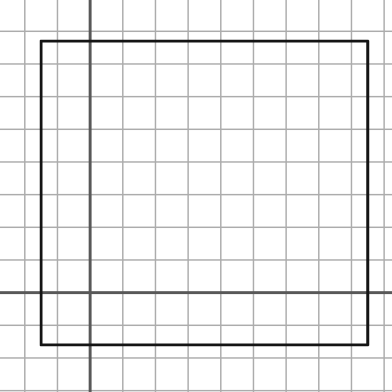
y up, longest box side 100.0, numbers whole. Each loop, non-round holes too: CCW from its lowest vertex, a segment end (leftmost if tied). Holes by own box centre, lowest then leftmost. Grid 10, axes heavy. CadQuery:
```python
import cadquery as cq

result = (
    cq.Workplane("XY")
    .moveTo(-15.0, -16.0)
    .lineTo(85.0, -16.0)
    .lineTo(85.0, 77.0)
    .lineTo(-15.0, 77.0)
    .close()
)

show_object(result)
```